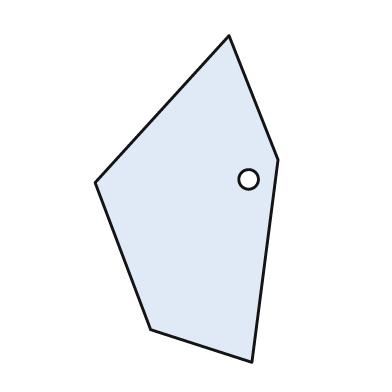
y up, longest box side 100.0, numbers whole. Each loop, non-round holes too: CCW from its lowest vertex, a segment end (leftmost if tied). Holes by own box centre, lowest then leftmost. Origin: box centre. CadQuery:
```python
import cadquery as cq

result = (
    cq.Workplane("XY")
    .moveTo(20.0, -50.0)
    .lineTo(28.0, 12.0)
    .lineTo(13.0, 50.0)
    .lineTo(-28.0, 5.0)
    .lineTo(-11.0, -40.0)
    .close()
    .moveTo(19.0, 6.0)
    .circle(3.0)
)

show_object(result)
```